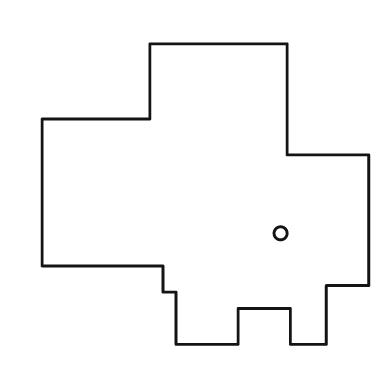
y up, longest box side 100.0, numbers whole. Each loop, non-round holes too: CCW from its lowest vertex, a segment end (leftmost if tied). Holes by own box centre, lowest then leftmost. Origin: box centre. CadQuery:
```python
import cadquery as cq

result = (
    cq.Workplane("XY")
    .moveTo(-9.0, -46.0)
    .lineTo(10.0, -46.0)
    .lineTo(10.0, -35.0)
    .lineTo(26.0, -35.0)
    .lineTo(26.0, -46.0)
    .lineTo(37.0, -46.0)
    .lineTo(37.0, -28.0)
    .lineTo(50.0, -28.0)
    .lineTo(50.0, 12.0)
    .lineTo(25.0, 12.0)
    .lineTo(25.0, 46.0)
    .lineTo(-17.0, 46.0)
    .lineTo(-17.0, 23.0)
    .lineTo(-50.0, 23.0)
    .lineTo(-50.0, -22.0)
    .lineTo(-13.0, -22.0)
    .lineTo(-13.0, -30.0)
    .lineTo(-9.0, -30.0)
    .close()
    .moveTo(23.0, -12.0)
    .circle(2.0)
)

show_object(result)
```